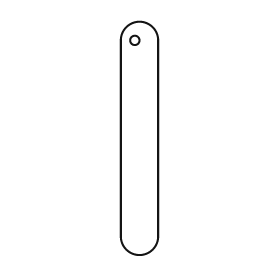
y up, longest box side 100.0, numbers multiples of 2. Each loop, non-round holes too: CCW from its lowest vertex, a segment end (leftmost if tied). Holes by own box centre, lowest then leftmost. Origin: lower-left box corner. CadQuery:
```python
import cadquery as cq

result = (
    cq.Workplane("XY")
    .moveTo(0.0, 8.0)
    .threePointArc((8.0, 0.0), (16.0, 8.0))
    .lineTo(16.0, 92.0)
    .threePointArc((8.0, 100.0), (0.0, 92.0))
    .close()
    .moveTo(6.0, 92.0)
    .circle(2.0)
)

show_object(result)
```